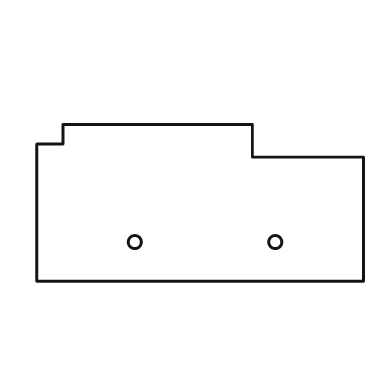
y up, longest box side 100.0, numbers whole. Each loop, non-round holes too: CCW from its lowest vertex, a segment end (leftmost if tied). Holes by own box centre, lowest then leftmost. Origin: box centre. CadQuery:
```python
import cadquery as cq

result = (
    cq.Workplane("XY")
    .moveTo(-50.0, -24.0)
    .lineTo(50.0, -24.0)
    .lineTo(50.0, 14.0)
    .lineTo(16.0, 14.0)
    .lineTo(16.0, 24.0)
    .lineTo(-42.0, 24.0)
    .lineTo(-42.0, 18.0)
    .lineTo(-50.0, 18.0)
    .close()
    .moveTo(-20.0, -12.0)
    .circle(2.0)
    .moveTo(23.0, -12.0)
    .circle(2.0)
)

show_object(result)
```